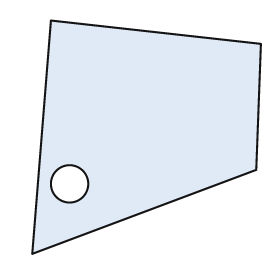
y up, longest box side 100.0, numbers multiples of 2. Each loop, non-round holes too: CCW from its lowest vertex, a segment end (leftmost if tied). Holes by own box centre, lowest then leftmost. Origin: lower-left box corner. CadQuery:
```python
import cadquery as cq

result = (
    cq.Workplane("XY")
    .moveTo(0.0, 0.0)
    .lineTo(96.0, 36.0)
    .lineTo(98.0, 90.0)
    .lineTo(8.0, 100.0)
    .close()
    .moveTo(16.0, 30.0)
    .circle(8.0)
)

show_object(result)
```